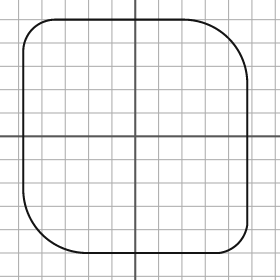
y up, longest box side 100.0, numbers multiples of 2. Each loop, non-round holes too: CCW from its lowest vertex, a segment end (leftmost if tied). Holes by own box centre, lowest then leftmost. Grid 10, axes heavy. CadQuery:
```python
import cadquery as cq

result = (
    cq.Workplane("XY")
    .moveTo(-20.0, -50.0)
    .lineTo(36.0, -50.0)
    .threePointArc((44.0, -46.0), (48.0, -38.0))
    .lineTo(48.0, 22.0)
    .threePointArc((40.0, 42.0), (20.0, 50.0))
    .lineTo(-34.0, 50.0)
    .threePointArc((-44.0, 46.0), (-48.0, 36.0))
    .lineTo(-48.0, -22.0)
    .threePointArc((-40.0, -42.0), (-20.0, -50.0))
    .close()
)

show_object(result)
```